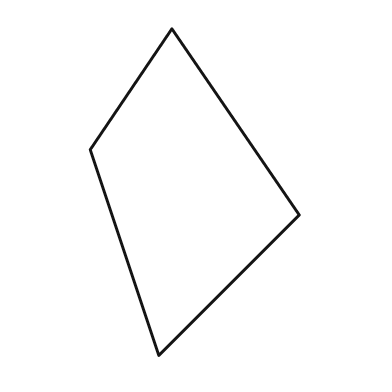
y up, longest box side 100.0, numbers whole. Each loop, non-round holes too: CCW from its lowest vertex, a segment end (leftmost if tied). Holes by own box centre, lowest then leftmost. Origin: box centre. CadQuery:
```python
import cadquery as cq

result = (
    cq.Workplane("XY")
    .moveTo(-11.0, -50.0)
    .lineTo(32.0, -7.0)
    .lineTo(-7.0, 50.0)
    .lineTo(-32.0, 13.0)
    .close()
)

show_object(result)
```